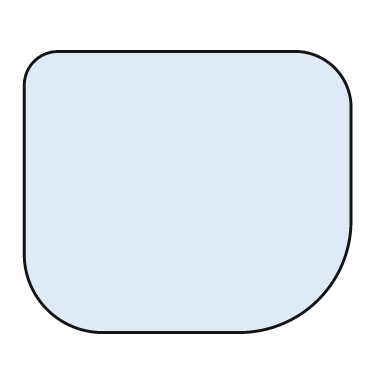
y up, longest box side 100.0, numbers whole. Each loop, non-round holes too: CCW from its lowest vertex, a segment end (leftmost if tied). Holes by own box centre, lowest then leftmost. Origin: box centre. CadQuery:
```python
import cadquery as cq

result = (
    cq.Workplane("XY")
    .moveTo(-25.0, -43.0)
    .lineTo(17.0, -43.0)
    .threePointArc((40.0, -33.0), (50.0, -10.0))
    .lineTo(50.0, 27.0)
    .threePointArc((45.0, 38.0), (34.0, 43.0))
    .lineTo(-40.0, 43.0)
    .threePointArc((-47.0, 40.0), (-50.0, 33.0))
    .lineTo(-50.0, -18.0)
    .threePointArc((-43.0, -36.0), (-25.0, -43.0))
    .close()
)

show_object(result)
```